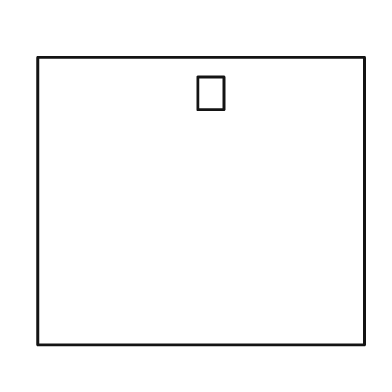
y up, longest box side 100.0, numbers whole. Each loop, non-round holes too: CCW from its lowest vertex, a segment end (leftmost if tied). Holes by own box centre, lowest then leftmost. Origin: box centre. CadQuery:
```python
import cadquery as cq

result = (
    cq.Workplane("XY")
    .moveTo(-50.0, -44.0)
    .lineTo(50.0, -44.0)
    .lineTo(50.0, 44.0)
    .lineTo(-50.0, 44.0)
    .close()
    .moveTo(-1.0, 28.0)
    .lineTo(7.0, 28.0)
    .lineTo(7.0, 38.0)
    .lineTo(-1.0, 38.0)
    .close()
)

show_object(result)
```